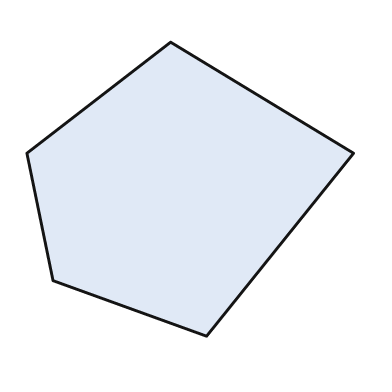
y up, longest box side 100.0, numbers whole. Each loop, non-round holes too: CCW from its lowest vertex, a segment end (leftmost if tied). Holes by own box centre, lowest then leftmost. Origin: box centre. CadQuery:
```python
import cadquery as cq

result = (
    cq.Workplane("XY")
    .moveTo(5.0, -45.0)
    .lineTo(50.0, 11.0)
    .lineTo(-6.0, 45.0)
    .lineTo(-50.0, 11.0)
    .lineTo(-42.0, -28.0)
    .close()
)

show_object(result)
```